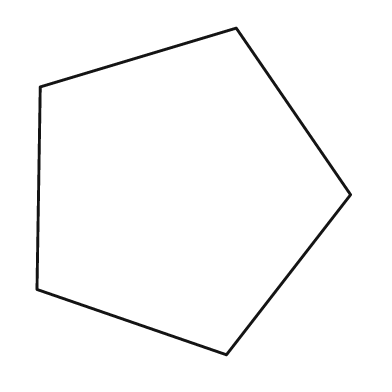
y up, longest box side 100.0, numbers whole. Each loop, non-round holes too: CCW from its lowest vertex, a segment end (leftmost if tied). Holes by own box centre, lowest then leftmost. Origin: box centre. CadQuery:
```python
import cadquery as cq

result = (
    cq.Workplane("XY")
    .moveTo(10.0, -50.0)
    .lineTo(48.0, -1.0)
    .lineTo(13.0, 50.0)
    .lineTo(-47.0, 32.0)
    .lineTo(-48.0, -30.0)
    .close()
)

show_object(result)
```